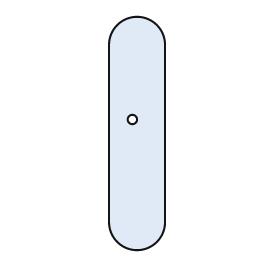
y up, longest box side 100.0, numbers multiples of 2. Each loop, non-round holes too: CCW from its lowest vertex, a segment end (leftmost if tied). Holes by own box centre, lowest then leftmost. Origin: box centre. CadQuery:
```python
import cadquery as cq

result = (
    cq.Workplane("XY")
    .moveTo(-12.0, -38.0)
    .threePointArc((0.0, -50.0), (12.0, -38.0))
    .lineTo(12.0, 38.0)
    .threePointArc((0.0, 50.0), (-12.0, 38.0))
    .close()
    .moveTo(-2.0, 6.0)
    .circle(2.0)
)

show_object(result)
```